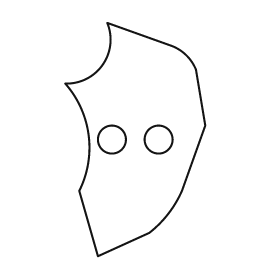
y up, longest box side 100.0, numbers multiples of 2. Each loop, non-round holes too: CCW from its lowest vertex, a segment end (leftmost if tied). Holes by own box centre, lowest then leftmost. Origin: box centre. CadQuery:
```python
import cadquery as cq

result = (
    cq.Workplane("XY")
    .moveTo(-16.0, -50.0)
    .lineTo(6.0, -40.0)
    .threePointArc((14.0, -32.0), (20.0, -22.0))
    .lineTo(30.0, 6.0)
    .lineTo(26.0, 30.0)
    .threePointArc((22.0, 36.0), (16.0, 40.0))
    .lineTo(-12.0, 50.0)
    .threePointArc((-14.0, 32.0), (-30.0, 24.0))
    .threePointArc((-20.0, 2.0), (-24.0, -22.0))
    .close()
    .moveTo(-10.0, 0.0)
    .circle(6.0)
    .moveTo(10.0, 0.0)
    .circle(6.0)
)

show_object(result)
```